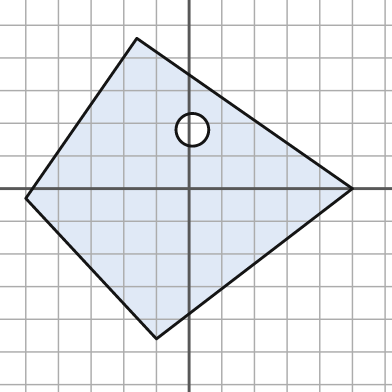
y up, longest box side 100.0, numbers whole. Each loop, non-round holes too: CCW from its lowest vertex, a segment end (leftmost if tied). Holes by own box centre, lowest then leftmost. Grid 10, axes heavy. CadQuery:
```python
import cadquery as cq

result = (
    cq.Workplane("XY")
    .moveTo(-10.0, -46.0)
    .lineTo(50.0, 0.0)
    .lineTo(-16.0, 46.0)
    .lineTo(-50.0, -3.0)
    .close()
    .moveTo(1.0, 18.0)
    .circle(5.0)
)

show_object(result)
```